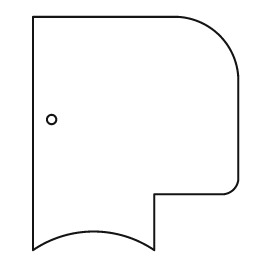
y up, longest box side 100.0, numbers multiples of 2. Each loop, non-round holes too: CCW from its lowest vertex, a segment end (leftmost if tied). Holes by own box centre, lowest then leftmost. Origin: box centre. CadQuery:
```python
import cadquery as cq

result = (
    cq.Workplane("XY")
    .moveTo(-44.0, -50.0)
    .threePointArc((-18.0, -42.0), (8.0, -50.0))
    .lineTo(8.0, -26.0)
    .lineTo(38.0, -26.0)
    .threePointArc((42.0, -24.0), (44.0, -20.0))
    .lineTo(44.0, 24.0)
    .threePointArc((36.0, 42.0), (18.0, 50.0))
    .lineTo(-44.0, 50.0)
    .close()
    .moveTo(-36.0, 6.0)
    .circle(2.0)
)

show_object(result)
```